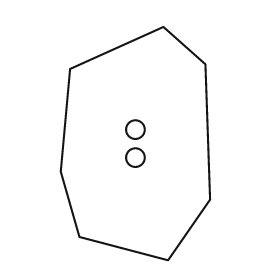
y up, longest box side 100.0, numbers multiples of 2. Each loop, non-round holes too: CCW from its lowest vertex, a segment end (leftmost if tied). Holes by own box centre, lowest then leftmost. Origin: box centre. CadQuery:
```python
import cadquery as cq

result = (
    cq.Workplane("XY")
    .moveTo(14.0, -50.0)
    .lineTo(32.0, -24.0)
    .lineTo(30.0, 34.0)
    .lineTo(12.0, 50.0)
    .lineTo(-28.0, 32.0)
    .lineTo(-32.0, -12.0)
    .lineTo(-24.0, -40.0)
    .close()
    .moveTo(0.0, -6.0)
    .circle(4.0)
    .moveTo(0.0, 6.0)
    .circle(4.0)
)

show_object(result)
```